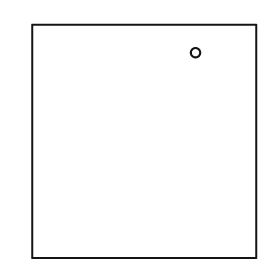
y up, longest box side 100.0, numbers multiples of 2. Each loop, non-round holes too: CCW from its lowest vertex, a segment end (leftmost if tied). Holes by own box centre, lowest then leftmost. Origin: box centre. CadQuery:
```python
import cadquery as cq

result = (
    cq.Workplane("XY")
    .moveTo(-48.0, -50.0)
    .lineTo(48.0, -50.0)
    .lineTo(48.0, 50.0)
    .lineTo(-48.0, 50.0)
    .close()
    .moveTo(22.0, 38.0)
    .circle(2.0)
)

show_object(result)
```